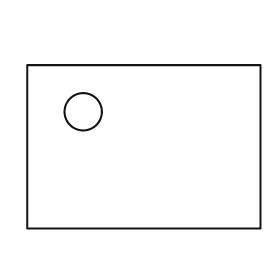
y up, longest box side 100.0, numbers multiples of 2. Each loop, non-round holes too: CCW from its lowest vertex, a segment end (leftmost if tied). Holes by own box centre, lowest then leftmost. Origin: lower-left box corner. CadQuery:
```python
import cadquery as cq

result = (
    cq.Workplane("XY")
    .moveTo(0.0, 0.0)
    .lineTo(100.0, 0.0)
    .lineTo(100.0, 70.0)
    .lineTo(0.0, 70.0)
    .close()
    .moveTo(24.0, 50.0)
    .circle(8.0)
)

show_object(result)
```